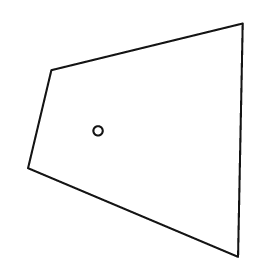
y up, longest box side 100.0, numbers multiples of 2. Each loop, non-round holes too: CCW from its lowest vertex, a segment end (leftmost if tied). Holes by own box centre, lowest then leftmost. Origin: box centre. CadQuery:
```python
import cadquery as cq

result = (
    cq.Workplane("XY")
    .moveTo(44.0, -50.0)
    .lineTo(46.0, 50.0)
    .lineTo(-36.0, 30.0)
    .lineTo(-46.0, -12.0)
    .close()
    .moveTo(-16.0, 4.0)
    .circle(2.0)
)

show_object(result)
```